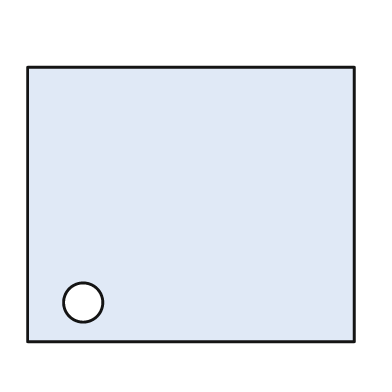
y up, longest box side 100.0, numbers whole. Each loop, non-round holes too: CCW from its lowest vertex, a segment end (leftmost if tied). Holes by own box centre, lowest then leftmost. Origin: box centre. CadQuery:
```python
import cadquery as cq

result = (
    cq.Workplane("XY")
    .moveTo(-50.0, -42.0)
    .lineTo(50.0, -42.0)
    .lineTo(50.0, 42.0)
    .lineTo(-50.0, 42.0)
    .close()
    .moveTo(-33.0, -30.0)
    .circle(6.0)
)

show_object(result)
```